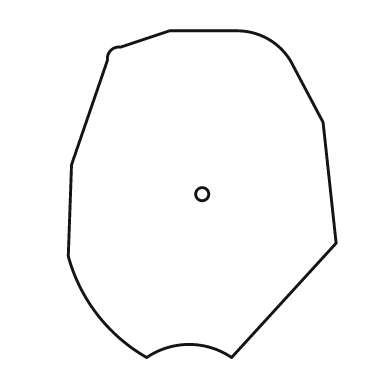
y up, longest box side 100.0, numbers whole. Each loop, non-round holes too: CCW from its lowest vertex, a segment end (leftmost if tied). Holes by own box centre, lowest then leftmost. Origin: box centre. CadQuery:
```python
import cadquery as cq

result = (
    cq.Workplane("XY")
    .moveTo(-17.0, -50.0)
    .threePointArc((-4.0, -46.0), (9.0, -50.0))
    .lineTo(41.0, -15.0)
    .lineTo(37.0, 22.0)
    .lineTo(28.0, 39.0)
    .threePointArc((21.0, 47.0), (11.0, 50.0))
    .lineTo(-10.0, 50.0)
    .lineTo(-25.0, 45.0)
    .threePointArc((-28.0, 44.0), (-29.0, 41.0))
    .lineTo(-40.0, 9.0)
    .lineTo(-41.0, -19.0)
    .threePointArc((-32.0, -37.0), (-17.0, -50.0))
    .close()
    .moveTo(0.0, 0.0)
    .circle(2.0)
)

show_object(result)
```